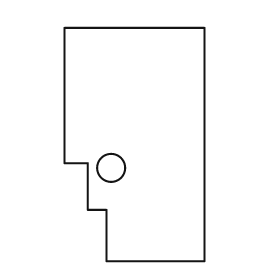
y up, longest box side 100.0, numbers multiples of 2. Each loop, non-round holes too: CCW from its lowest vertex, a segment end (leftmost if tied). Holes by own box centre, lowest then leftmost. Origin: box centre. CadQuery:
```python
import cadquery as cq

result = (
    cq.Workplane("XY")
    .moveTo(-12.0, -50.0)
    .lineTo(30.0, -50.0)
    .lineTo(30.0, 50.0)
    .lineTo(-30.0, 50.0)
    .lineTo(-30.0, -8.0)
    .lineTo(-20.0, -8.0)
    .lineTo(-20.0, -28.0)
    .lineTo(-12.0, -28.0)
    .close()
    .moveTo(-10.0, -10.0)
    .circle(6.0)
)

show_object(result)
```